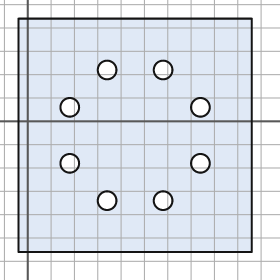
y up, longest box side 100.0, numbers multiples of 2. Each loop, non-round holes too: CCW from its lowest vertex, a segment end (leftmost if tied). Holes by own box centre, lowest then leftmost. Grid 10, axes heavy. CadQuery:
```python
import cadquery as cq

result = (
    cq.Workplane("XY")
    .moveTo(-4.0, -56.0)
    .lineTo(96.0, -56.0)
    .lineTo(96.0, 44.0)
    .lineTo(-4.0, 44.0)
    .close()
    .moveTo(34.0, -34.0)
    .circle(4.0)
    .moveTo(58.0, -34.0)
    .circle(4.0)
    .moveTo(18.0, -18.0)
    .circle(4.0)
    .moveTo(74.0, -18.0)
    .circle(4.0)
    .moveTo(18.0, 6.0)
    .circle(4.0)
    .moveTo(74.0, 6.0)
    .circle(4.0)
    .moveTo(34.0, 22.0)
    .circle(4.0)
    .moveTo(58.0, 22.0)
    .circle(4.0)
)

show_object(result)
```